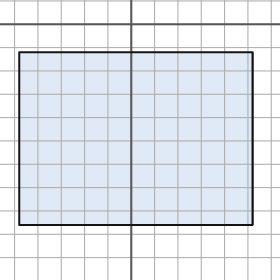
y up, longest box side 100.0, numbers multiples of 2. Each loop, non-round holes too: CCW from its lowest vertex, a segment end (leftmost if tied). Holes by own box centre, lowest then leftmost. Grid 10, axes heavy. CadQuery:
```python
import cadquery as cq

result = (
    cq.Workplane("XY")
    .moveTo(-48.0, -86.0)
    .lineTo(52.0, -86.0)
    .lineTo(52.0, -12.0)
    .lineTo(-48.0, -12.0)
    .close()
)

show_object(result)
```